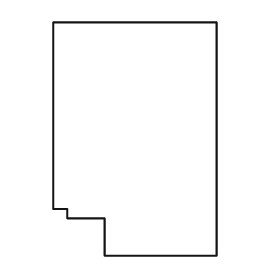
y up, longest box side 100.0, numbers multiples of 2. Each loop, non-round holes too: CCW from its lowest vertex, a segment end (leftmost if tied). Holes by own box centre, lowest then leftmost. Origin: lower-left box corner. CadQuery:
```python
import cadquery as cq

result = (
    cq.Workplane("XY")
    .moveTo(22.0, 0.0)
    .lineTo(70.0, 0.0)
    .lineTo(70.0, 100.0)
    .lineTo(0.0, 100.0)
    .lineTo(0.0, 20.0)
    .lineTo(6.0, 20.0)
    .lineTo(6.0, 16.0)
    .lineTo(22.0, 16.0)
    .close()
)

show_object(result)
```